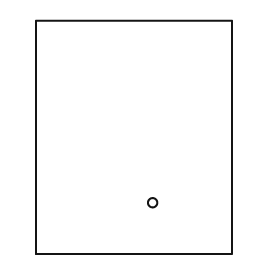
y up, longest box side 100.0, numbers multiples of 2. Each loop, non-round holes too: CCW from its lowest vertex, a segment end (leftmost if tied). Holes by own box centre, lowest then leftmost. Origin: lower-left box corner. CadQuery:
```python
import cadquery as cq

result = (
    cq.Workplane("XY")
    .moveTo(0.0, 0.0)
    .lineTo(84.0, 0.0)
    .lineTo(84.0, 100.0)
    .lineTo(0.0, 100.0)
    .close()
    .moveTo(50.0, 22.0)
    .circle(2.0)
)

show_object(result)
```